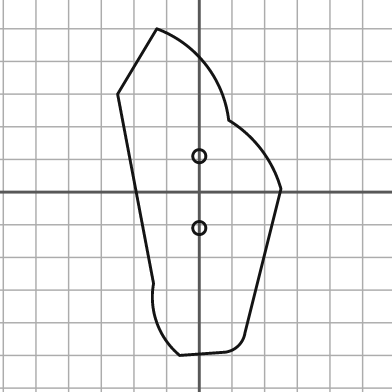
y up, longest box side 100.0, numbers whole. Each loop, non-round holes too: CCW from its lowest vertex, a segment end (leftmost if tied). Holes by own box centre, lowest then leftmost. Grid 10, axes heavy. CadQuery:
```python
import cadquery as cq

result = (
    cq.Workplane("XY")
    .moveTo(-6.0, -50.0)
    .lineTo(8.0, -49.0)
    .threePointArc((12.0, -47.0), (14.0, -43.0))
    .lineTo(25.0, 1.0)
    .threePointArc((19.0, 13.0), (9.0, 22.0))
    .threePointArc((2.0, 39.0), (-13.0, 50.0))
    .lineTo(-25.0, 30.0)
    .lineTo(-14.0, -28.0)
    .threePointArc((-13.0, -40.0), (-6.0, -50.0))
    .close()
    .moveTo(0.0, -11.0)
    .circle(2.0)
    .moveTo(0.0, 11.0)
    .circle(2.0)
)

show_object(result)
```